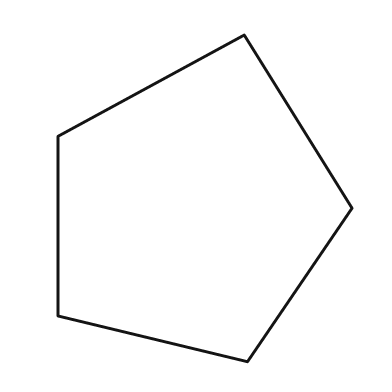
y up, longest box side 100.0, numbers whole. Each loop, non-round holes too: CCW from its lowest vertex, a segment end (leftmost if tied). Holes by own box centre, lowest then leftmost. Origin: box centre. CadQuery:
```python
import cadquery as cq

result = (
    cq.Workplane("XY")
    .moveTo(13.0, -50.0)
    .lineTo(45.0, -3.0)
    .lineTo(12.0, 50.0)
    .lineTo(-45.0, 19.0)
    .lineTo(-45.0, -36.0)
    .close()
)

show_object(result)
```